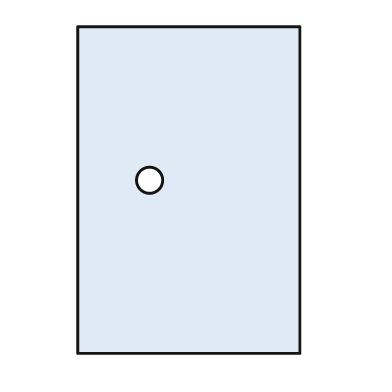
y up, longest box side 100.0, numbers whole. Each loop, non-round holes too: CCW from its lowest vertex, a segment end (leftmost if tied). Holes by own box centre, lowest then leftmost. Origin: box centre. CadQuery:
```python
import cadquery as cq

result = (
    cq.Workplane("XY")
    .moveTo(-34.0, -50.0)
    .lineTo(34.0, -50.0)
    .lineTo(34.0, 50.0)
    .lineTo(-34.0, 50.0)
    .close()
    .moveTo(-12.0, 3.0)
    .circle(4.0)
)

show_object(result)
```